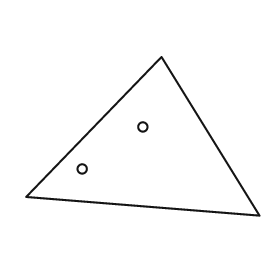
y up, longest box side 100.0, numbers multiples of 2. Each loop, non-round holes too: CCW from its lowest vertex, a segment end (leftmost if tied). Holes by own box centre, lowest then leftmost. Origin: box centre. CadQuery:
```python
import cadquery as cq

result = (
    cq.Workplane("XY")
    .moveTo(50.0, -34.0)
    .lineTo(8.0, 34.0)
    .lineTo(-50.0, -26.0)
    .close()
    .moveTo(-26.0, -14.0)
    .circle(2.0)
    .moveTo(0.0, 4.0)
    .circle(2.0)
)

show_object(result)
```